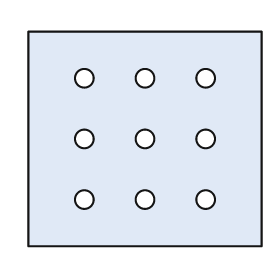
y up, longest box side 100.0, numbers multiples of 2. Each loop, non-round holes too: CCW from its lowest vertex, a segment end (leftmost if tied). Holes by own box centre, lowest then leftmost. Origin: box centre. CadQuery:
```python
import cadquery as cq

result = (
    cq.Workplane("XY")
    .moveTo(-50.0, -46.0)
    .lineTo(50.0, -46.0)
    .lineTo(50.0, 46.0)
    .lineTo(-50.0, 46.0)
    .close()
    .moveTo(-26.0, -26.0)
    .circle(4.0)
    .moveTo(0.0, -26.0)
    .circle(4.0)
    .moveTo(26.0, -26.0)
    .circle(4.0)
    .moveTo(-26.0, 0.0)
    .circle(4.0)
    .moveTo(0.0, 0.0)
    .circle(4.0)
    .moveTo(26.0, 0.0)
    .circle(4.0)
    .moveTo(-26.0, 26.0)
    .circle(4.0)
    .moveTo(0.0, 26.0)
    .circle(4.0)
    .moveTo(26.0, 26.0)
    .circle(4.0)
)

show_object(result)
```